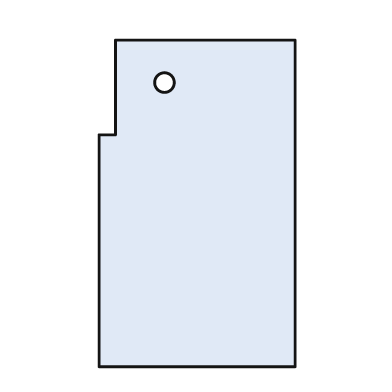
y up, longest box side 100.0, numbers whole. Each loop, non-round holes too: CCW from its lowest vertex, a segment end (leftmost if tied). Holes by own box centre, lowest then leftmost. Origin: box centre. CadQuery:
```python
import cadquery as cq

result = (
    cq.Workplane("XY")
    .moveTo(-30.0, -50.0)
    .lineTo(30.0, -50.0)
    .lineTo(30.0, 50.0)
    .lineTo(-25.0, 50.0)
    .lineTo(-25.0, 21.0)
    .lineTo(-30.0, 21.0)
    .close()
    .moveTo(-10.0, 37.0)
    .circle(3.0)
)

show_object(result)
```